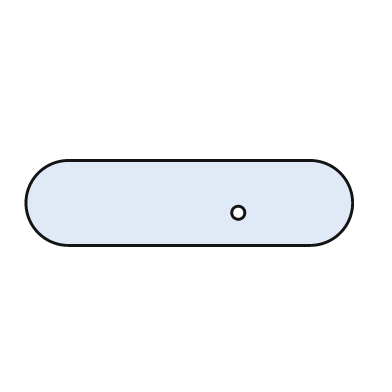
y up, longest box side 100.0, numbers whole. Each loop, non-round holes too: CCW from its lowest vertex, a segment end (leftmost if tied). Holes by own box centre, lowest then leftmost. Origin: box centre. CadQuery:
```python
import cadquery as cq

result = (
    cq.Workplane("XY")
    .moveTo(-37.0, -13.0)
    .lineTo(37.0, -13.0)
    .threePointArc((50.0, 0.0), (37.0, 13.0))
    .lineTo(-37.0, 13.0)
    .threePointArc((-50.0, 0.0), (-37.0, -13.0))
    .close()
    .moveTo(15.0, -3.0)
    .circle(2.0)
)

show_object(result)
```